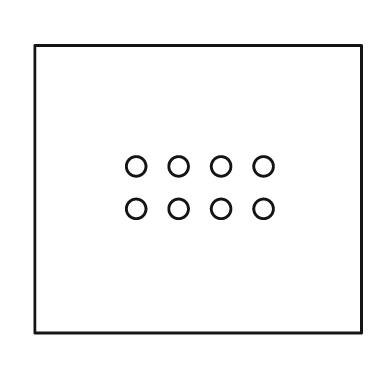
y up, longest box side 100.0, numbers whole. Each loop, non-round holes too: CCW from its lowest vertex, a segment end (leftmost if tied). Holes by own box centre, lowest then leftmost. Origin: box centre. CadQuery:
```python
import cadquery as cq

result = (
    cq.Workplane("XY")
    .moveTo(-50.0, -44.0)
    .lineTo(50.0, -44.0)
    .lineTo(50.0, 44.0)
    .lineTo(-50.0, 44.0)
    .close()
    .moveTo(-19.0, -6.0)
    .circle(3.0)
    .moveTo(-6.0, -6.0)
    .circle(3.0)
    .moveTo(7.0, -6.0)
    .circle(3.0)
    .moveTo(20.0, -6.0)
    .circle(3.0)
    .moveTo(-19.0, 7.0)
    .circle(3.0)
    .moveTo(-6.0, 7.0)
    .circle(3.0)
    .moveTo(7.0, 7.0)
    .circle(3.0)
    .moveTo(20.0, 7.0)
    .circle(3.0)
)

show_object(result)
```